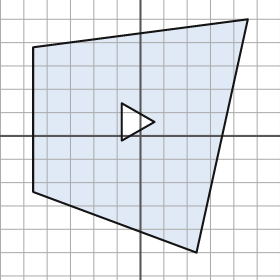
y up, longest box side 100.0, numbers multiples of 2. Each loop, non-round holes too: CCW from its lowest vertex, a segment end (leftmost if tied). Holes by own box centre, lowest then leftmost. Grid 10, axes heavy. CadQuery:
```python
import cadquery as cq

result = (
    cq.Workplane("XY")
    .moveTo(24.0, -50.0)
    .lineTo(46.0, 50.0)
    .lineTo(-46.0, 38.0)
    .lineTo(-46.0, -24.0)
    .close()
    .moveTo(-8.0, -2.0)
    .lineTo(6.0, 6.0)
    .lineTo(-8.0, 14.0)
    .close()
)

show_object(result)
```